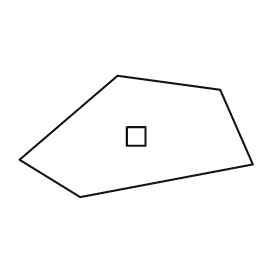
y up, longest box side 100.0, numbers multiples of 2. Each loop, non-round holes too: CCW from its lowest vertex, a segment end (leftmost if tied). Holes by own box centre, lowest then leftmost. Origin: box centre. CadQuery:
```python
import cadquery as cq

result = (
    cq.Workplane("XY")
    .moveTo(-24.0, -26.0)
    .lineTo(50.0, -12.0)
    .lineTo(36.0, 20.0)
    .lineTo(-8.0, 26.0)
    .lineTo(-50.0, -10.0)
    .close()
    .moveTo(-4.0, -4.0)
    .lineTo(4.0, -4.0)
    .lineTo(4.0, 4.0)
    .lineTo(-4.0, 4.0)
    .close()
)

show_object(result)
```